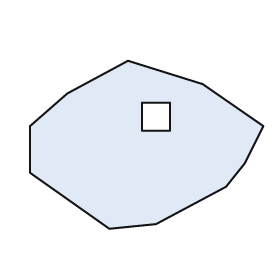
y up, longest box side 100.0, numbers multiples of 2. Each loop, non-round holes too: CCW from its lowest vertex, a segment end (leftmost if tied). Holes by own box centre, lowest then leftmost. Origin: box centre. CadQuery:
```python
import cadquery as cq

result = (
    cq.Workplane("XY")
    .moveTo(-16.0, -36.0)
    .lineTo(4.0, -34.0)
    .lineTo(34.0, -18.0)
    .lineTo(42.0, -8.0)
    .lineTo(50.0, 8.0)
    .lineTo(24.0, 26.0)
    .lineTo(-8.0, 36.0)
    .lineTo(-34.0, 22.0)
    .lineTo(-50.0, 8.0)
    .lineTo(-50.0, -12.0)
    .close()
    .moveTo(-2.0, 6.0)
    .lineTo(10.0, 6.0)
    .lineTo(10.0, 18.0)
    .lineTo(-2.0, 18.0)
    .close()
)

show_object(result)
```